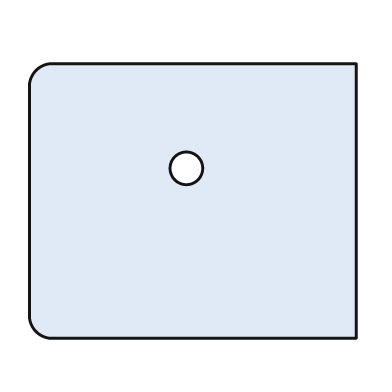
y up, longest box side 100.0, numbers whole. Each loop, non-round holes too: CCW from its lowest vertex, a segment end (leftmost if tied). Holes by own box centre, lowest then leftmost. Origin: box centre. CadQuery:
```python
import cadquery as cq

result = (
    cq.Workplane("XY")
    .moveTo(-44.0, -42.0)
    .lineTo(50.0, -42.0)
    .lineTo(50.0, 42.0)
    .lineTo(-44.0, 42.0)
    .threePointArc((-48.0, 40.0), (-50.0, 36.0))
    .lineTo(-50.0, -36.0)
    .threePointArc((-48.0, -40.0), (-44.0, -42.0))
    .close()
    .moveTo(-2.0, 10.0)
    .circle(5.0)
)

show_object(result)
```